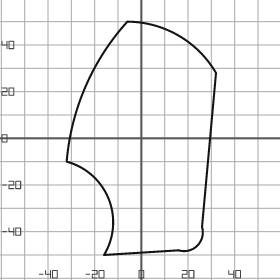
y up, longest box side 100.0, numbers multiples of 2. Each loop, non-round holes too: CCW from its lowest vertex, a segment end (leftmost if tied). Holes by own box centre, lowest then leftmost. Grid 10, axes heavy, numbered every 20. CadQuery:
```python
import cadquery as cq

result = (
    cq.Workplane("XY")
    .moveTo(-16.0, -50.0)
    .lineTo(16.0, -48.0)
    .threePointArc((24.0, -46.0), (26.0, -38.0))
    .lineTo(32.0, 28.0)
    .threePointArc((16.0, 44.0), (-6.0, 50.0))
    .threePointArc((-24.0, 22.0), (-32.0, -10.0))
    .threePointArc((-14.0, -26.0), (-16.0, -50.0))
    .close()
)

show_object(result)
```